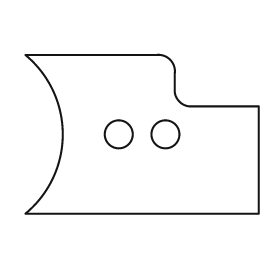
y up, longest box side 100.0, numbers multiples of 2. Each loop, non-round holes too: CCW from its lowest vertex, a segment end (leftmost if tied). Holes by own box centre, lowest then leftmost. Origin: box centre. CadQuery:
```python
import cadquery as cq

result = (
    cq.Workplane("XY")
    .moveTo(-50.0, -34.0)
    .lineTo(50.0, -34.0)
    .lineTo(50.0, 12.0)
    .lineTo(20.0, 12.0)
    .threePointArc((16.0, 14.0), (14.0, 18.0))
    .lineTo(14.0, 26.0)
    .threePointArc((12.0, 32.0), (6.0, 34.0))
    .lineTo(-50.0, 34.0)
    .threePointArc((-34.0, 0.0), (-50.0, -34.0))
    .close()
    .moveTo(-10.0, 0.0)
    .circle(6.0)
    .moveTo(10.0, 0.0)
    .circle(6.0)
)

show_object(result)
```